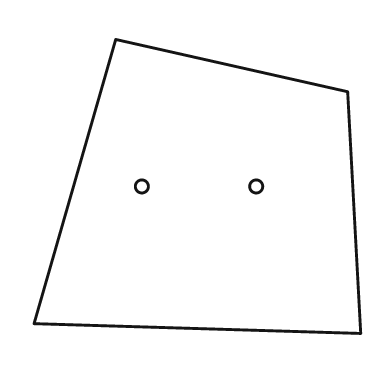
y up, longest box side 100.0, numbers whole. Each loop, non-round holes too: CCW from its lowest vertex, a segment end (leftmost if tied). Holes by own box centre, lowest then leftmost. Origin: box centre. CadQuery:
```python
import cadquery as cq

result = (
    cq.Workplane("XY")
    .moveTo(50.0, -45.0)
    .lineTo(46.0, 29.0)
    .lineTo(-25.0, 45.0)
    .lineTo(-50.0, -42.0)
    .close()
    .moveTo(-17.0, 0.0)
    .circle(2.0)
    .moveTo(18.0, 0.0)
    .circle(2.0)
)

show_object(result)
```